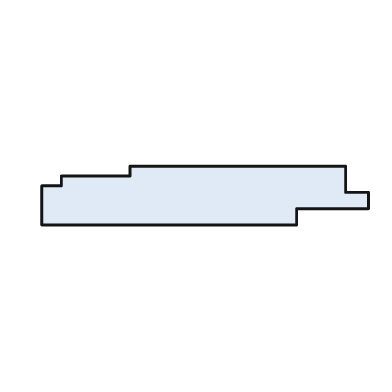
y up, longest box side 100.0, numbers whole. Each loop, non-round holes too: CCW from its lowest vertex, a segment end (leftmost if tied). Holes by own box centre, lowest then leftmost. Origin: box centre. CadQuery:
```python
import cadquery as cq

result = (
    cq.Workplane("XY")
    .moveTo(-50.0, -9.0)
    .lineTo(28.0, -9.0)
    .lineTo(28.0, -4.0)
    .lineTo(50.0, -4.0)
    .lineTo(50.0, 1.0)
    .lineTo(43.0, 1.0)
    .lineTo(43.0, 9.0)
    .lineTo(-23.0, 9.0)
    .lineTo(-23.0, 6.0)
    .lineTo(-44.0, 6.0)
    .lineTo(-44.0, 3.0)
    .lineTo(-50.0, 3.0)
    .close()
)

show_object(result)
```